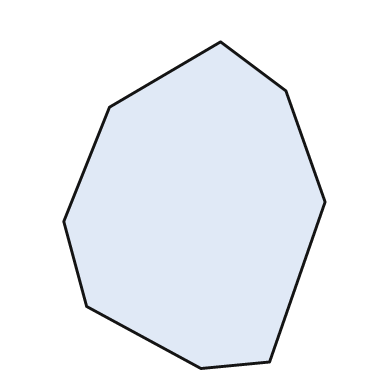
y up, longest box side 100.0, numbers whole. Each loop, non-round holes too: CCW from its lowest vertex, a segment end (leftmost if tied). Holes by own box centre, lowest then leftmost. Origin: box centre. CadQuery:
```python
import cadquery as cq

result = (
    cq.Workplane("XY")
    .moveTo(2.0, -50.0)
    .lineTo(23.0, -48.0)
    .lineTo(40.0, 1.0)
    .lineTo(28.0, 35.0)
    .lineTo(8.0, 50.0)
    .lineTo(-26.0, 30.0)
    .lineTo(-40.0, -5.0)
    .lineTo(-33.0, -31.0)
    .close()
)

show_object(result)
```